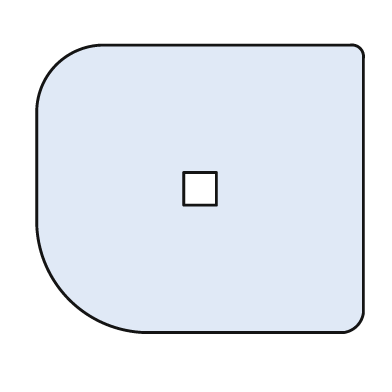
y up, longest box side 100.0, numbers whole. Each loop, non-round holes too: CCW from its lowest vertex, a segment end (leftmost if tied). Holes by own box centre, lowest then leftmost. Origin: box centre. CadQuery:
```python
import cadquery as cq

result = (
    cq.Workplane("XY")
    .moveTo(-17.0, -44.0)
    .lineTo(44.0, -44.0)
    .threePointArc((48.0, -42.0), (50.0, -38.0))
    .lineTo(50.0, 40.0)
    .threePointArc((49.0, 43.0), (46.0, 44.0))
    .lineTo(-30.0, 44.0)
    .threePointArc((-44.0, 38.0), (-50.0, 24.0))
    .lineTo(-50.0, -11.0)
    .threePointArc((-40.0, -34.0), (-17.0, -44.0))
    .close()
    .moveTo(-5.0, -5.0)
    .lineTo(5.0, -5.0)
    .lineTo(5.0, 5.0)
    .lineTo(-5.0, 5.0)
    .close()
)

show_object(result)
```